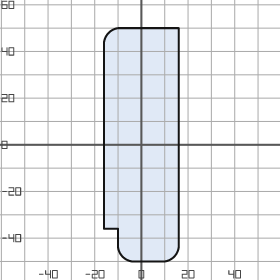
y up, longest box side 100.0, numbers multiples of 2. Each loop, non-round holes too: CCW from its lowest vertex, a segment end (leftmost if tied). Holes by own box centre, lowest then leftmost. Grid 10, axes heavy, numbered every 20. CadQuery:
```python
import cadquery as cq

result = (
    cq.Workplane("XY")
    .moveTo(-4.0, -50.0)
    .lineTo(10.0, -50.0)
    .threePointArc((14.0, -48.0), (16.0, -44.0))
    .lineTo(16.0, 50.0)
    .lineTo(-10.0, 50.0)
    .threePointArc((-14.0, 48.0), (-16.0, 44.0))
    .lineTo(-16.0, -36.0)
    .lineTo(-10.0, -36.0)
    .lineTo(-10.0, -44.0)
    .threePointArc((-8.0, -48.0), (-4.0, -50.0))
    .close()
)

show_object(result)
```